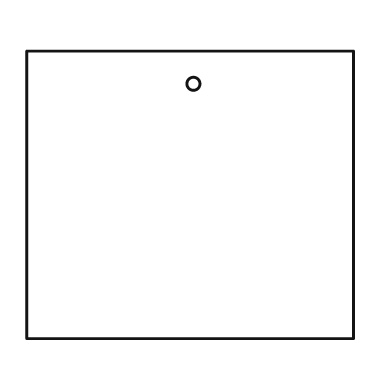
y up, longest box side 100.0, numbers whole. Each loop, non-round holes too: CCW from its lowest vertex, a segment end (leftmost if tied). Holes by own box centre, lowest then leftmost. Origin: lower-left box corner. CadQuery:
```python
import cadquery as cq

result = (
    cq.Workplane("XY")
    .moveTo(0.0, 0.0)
    .lineTo(100.0, 0.0)
    .lineTo(100.0, 88.0)
    .lineTo(0.0, 88.0)
    .close()
    .moveTo(51.0, 78.0)
    .circle(2.0)
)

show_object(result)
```